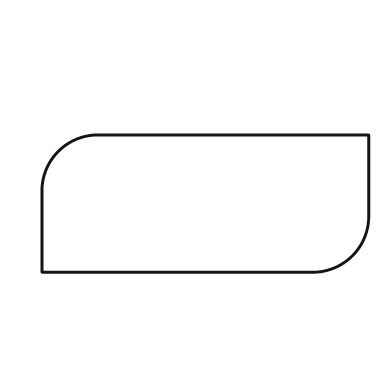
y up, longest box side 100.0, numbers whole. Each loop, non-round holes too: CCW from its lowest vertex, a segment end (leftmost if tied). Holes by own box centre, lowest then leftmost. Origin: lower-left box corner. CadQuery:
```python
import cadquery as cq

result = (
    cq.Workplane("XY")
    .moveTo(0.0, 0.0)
    .lineTo(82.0, 0.0)
    .threePointArc((95.0, 5.0), (100.0, 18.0))
    .lineTo(100.0, 42.0)
    .lineTo(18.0, 42.0)
    .threePointArc((5.0, 37.0), (0.0, 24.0))
    .close()
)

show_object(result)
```